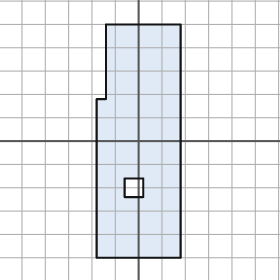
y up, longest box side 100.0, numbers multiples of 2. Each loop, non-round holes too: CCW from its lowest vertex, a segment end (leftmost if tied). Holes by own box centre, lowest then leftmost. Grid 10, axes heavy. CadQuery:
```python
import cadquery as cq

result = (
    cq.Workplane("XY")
    .moveTo(-18.0, -50.0)
    .lineTo(18.0, -50.0)
    .lineTo(18.0, 50.0)
    .lineTo(-14.0, 50.0)
    .lineTo(-14.0, 18.0)
    .lineTo(-18.0, 18.0)
    .close()
    .moveTo(-6.0, -24.0)
    .lineTo(2.0, -24.0)
    .lineTo(2.0, -16.0)
    .lineTo(-6.0, -16.0)
    .close()
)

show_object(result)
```